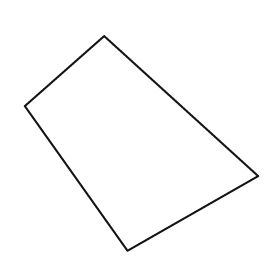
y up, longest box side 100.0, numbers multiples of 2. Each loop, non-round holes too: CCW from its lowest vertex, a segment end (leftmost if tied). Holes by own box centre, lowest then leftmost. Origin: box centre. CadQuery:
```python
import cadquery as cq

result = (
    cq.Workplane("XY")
    .moveTo(-6.0, -46.0)
    .lineTo(50.0, -14.0)
    .lineTo(-16.0, 46.0)
    .lineTo(-50.0, 16.0)
    .close()
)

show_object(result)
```